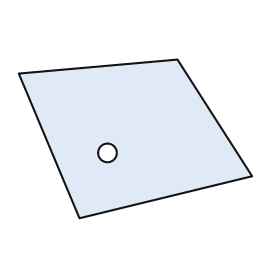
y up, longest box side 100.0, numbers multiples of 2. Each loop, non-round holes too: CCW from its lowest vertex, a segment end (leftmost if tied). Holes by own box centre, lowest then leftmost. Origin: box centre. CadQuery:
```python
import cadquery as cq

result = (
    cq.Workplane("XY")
    .moveTo(-24.0, -34.0)
    .lineTo(50.0, -16.0)
    .lineTo(18.0, 34.0)
    .lineTo(-50.0, 28.0)
    .close()
    .moveTo(-12.0, -6.0)
    .circle(4.0)
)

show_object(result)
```